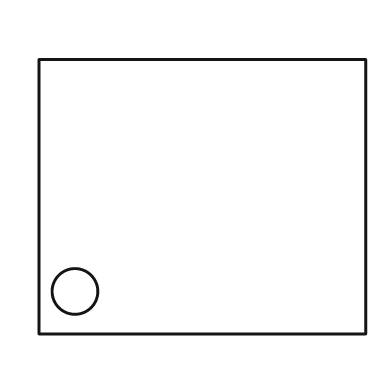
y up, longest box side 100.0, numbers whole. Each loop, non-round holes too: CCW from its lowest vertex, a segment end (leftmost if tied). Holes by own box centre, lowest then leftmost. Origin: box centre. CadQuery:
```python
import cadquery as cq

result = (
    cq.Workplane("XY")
    .moveTo(-50.0, -42.0)
    .lineTo(50.0, -42.0)
    .lineTo(50.0, 42.0)
    .lineTo(-50.0, 42.0)
    .close()
    .moveTo(-39.0, -29.0)
    .circle(7.0)
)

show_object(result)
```